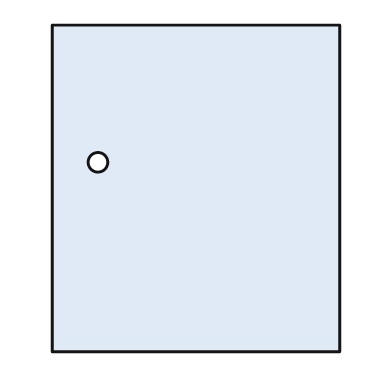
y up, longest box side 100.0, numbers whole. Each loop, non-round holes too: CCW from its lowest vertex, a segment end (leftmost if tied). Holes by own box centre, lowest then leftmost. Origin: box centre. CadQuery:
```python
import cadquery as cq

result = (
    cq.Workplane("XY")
    .moveTo(-44.0, -50.0)
    .lineTo(44.0, -50.0)
    .lineTo(44.0, 50.0)
    .lineTo(-44.0, 50.0)
    .close()
    .moveTo(-30.0, 8.0)
    .circle(3.0)
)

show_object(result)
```